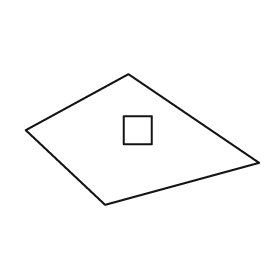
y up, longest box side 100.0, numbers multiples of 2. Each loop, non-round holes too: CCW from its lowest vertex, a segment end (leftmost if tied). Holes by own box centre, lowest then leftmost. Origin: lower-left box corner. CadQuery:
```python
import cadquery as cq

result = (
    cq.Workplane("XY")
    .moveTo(34.0, 0.0)
    .lineTo(100.0, 18.0)
    .lineTo(44.0, 56.0)
    .lineTo(0.0, 32.0)
    .close()
    .moveTo(42.0, 26.0)
    .lineTo(54.0, 26.0)
    .lineTo(54.0, 38.0)
    .lineTo(42.0, 38.0)
    .close()
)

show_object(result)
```